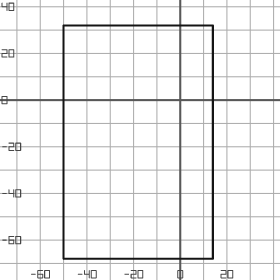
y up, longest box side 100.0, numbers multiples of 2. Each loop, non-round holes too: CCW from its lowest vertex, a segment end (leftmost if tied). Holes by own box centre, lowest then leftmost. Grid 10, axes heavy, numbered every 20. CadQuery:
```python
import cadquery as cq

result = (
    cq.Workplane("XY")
    .moveTo(-50.0, -68.0)
    .lineTo(14.0, -68.0)
    .lineTo(14.0, 32.0)
    .lineTo(-50.0, 32.0)
    .close()
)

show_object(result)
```